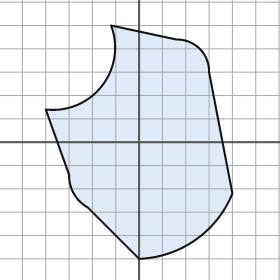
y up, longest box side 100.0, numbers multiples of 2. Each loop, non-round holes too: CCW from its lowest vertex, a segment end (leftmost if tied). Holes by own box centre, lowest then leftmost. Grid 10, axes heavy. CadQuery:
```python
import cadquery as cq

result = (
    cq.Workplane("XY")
    .moveTo(0.0, -50.0)
    .threePointArc((24.0, -42.0), (40.0, -22.0))
    .lineTo(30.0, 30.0)
    .threePointArc((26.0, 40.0), (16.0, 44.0))
    .lineTo(-12.0, 50.0)
    .threePointArc((-16.0, 24.0), (-40.0, 14.0))
    .lineTo(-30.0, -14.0)
    .threePointArc((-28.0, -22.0), (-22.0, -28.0))
    .close()
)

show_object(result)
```